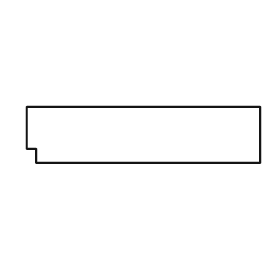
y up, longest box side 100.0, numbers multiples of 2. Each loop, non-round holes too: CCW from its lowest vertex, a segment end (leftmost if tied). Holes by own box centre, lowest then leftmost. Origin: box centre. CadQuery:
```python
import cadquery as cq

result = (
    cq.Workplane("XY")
    .moveTo(-46.0, -12.0)
    .lineTo(50.0, -12.0)
    .lineTo(50.0, 12.0)
    .lineTo(-50.0, 12.0)
    .lineTo(-50.0, -6.0)
    .lineTo(-46.0, -6.0)
    .close()
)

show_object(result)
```